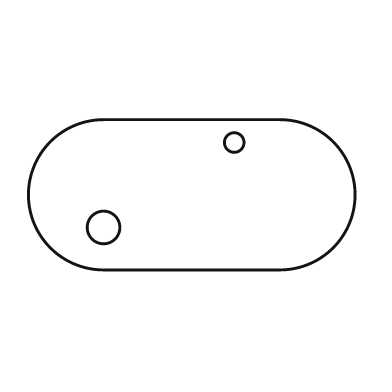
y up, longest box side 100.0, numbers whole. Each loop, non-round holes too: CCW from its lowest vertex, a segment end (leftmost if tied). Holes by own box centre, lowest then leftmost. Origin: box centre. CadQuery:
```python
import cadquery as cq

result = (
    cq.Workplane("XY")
    .moveTo(-27.0, -23.0)
    .lineTo(27.0, -23.0)
    .threePointArc((50.0, 0.0), (27.0, 23.0))
    .lineTo(-27.0, 23.0)
    .threePointArc((-50.0, 0.0), (-27.0, -23.0))
    .close()
    .moveTo(-27.0, -10.0)
    .circle(5.0)
    .moveTo(13.0, 16.0)
    .circle(3.0)
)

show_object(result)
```